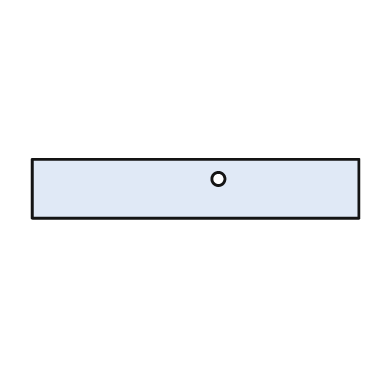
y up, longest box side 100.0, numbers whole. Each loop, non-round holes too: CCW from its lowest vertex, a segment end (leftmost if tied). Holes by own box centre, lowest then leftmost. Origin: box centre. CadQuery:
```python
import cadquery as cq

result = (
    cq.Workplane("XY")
    .moveTo(-50.0, -9.0)
    .lineTo(50.0, -9.0)
    .lineTo(50.0, 9.0)
    .lineTo(-50.0, 9.0)
    .close()
    .moveTo(7.0, 3.0)
    .circle(2.0)
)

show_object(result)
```